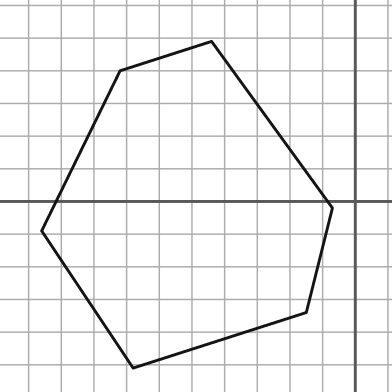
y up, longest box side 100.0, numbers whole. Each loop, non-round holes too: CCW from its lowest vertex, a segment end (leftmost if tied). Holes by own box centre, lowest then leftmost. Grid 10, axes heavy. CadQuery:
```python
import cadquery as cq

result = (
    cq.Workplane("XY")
    .moveTo(-68.0, -51.0)
    .lineTo(-15.0, -34.0)
    .lineTo(-7.0, -2.0)
    .lineTo(-44.0, 49.0)
    .lineTo(-72.0, 40.0)
    .lineTo(-96.0, -9.0)
    .close()
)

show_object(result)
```